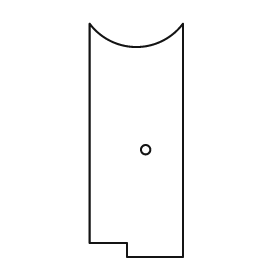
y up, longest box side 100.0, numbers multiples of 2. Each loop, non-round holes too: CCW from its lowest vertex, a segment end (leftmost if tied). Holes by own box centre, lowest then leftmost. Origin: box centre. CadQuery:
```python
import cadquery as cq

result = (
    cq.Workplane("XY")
    .moveTo(-4.0, -50.0)
    .lineTo(20.0, -50.0)
    .lineTo(20.0, 50.0)
    .threePointArc((0.0, 40.0), (-20.0, 50.0))
    .lineTo(-20.0, -44.0)
    .lineTo(-4.0, -44.0)
    .close()
    .moveTo(4.0, -4.0)
    .circle(2.0)
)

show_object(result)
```